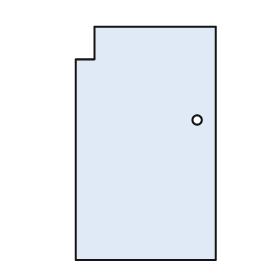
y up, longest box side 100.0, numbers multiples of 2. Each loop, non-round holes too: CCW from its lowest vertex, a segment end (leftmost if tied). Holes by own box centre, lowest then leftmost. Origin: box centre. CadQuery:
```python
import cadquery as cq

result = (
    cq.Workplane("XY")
    .moveTo(-30.0, -50.0)
    .lineTo(30.0, -50.0)
    .lineTo(30.0, 50.0)
    .lineTo(-22.0, 50.0)
    .lineTo(-22.0, 36.0)
    .lineTo(-30.0, 36.0)
    .close()
    .moveTo(22.0, 10.0)
    .circle(2.0)
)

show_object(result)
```